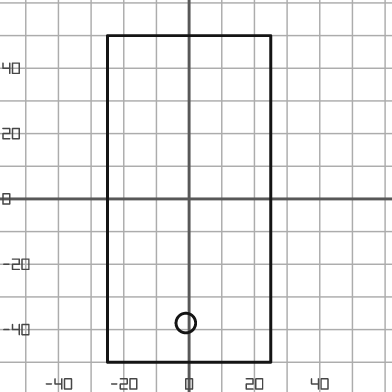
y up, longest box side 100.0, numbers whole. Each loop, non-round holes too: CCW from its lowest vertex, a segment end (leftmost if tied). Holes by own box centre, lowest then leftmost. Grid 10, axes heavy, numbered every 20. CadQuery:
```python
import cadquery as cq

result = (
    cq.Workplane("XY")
    .moveTo(-25.0, -50.0)
    .lineTo(25.0, -50.0)
    .lineTo(25.0, 50.0)
    .lineTo(-25.0, 50.0)
    .close()
    .moveTo(-1.0, -38.0)
    .circle(3.0)
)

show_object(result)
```